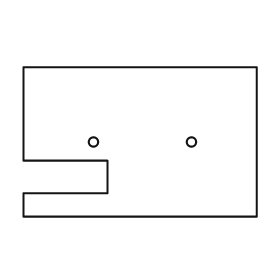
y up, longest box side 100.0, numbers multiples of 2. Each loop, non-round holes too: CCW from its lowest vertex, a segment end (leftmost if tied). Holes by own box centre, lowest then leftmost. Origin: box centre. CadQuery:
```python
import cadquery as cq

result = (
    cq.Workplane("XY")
    .moveTo(-50.0, -32.0)
    .lineTo(50.0, -32.0)
    .lineTo(50.0, 32.0)
    .lineTo(-50.0, 32.0)
    .lineTo(-50.0, -8.0)
    .lineTo(-14.0, -8.0)
    .lineTo(-14.0, -22.0)
    .lineTo(-50.0, -22.0)
    .close()
    .moveTo(-20.0, 0.0)
    .circle(2.0)
    .moveTo(22.0, 0.0)
    .circle(2.0)
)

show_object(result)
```